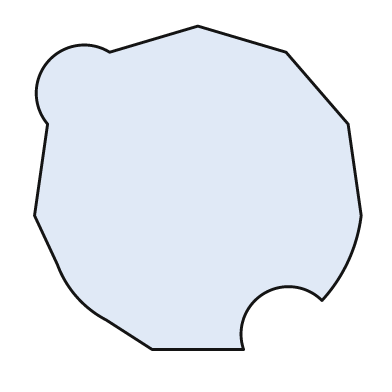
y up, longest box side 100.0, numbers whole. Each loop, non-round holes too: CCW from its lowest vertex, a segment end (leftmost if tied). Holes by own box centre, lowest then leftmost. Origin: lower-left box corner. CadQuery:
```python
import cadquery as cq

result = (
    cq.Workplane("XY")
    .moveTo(36.0, 0.0)
    .lineTo(64.0, 0.0)
    .threePointArc((70.0, 17.0), (88.0, 15.0))
    .threePointArc((96.0, 27.0), (100.0, 41.0))
    .lineTo(96.0, 69.0)
    .lineTo(77.0, 91.0)
    .lineTo(50.0, 99.0)
    .lineTo(23.0, 91.0)
    .threePointArc((4.0, 88.0), (4.0, 69.0))
    .lineTo(0.0, 41.0)
    .lineTo(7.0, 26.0)
    .threePointArc((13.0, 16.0), (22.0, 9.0))
    .close()
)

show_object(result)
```